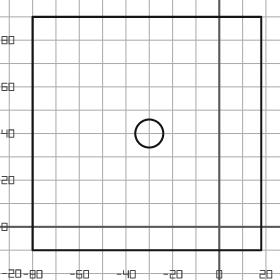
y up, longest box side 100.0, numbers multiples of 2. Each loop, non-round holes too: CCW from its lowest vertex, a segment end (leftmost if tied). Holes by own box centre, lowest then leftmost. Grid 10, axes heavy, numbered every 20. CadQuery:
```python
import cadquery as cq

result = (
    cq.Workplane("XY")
    .moveTo(-80.0, -10.0)
    .lineTo(18.0, -10.0)
    .lineTo(18.0, 90.0)
    .lineTo(-80.0, 90.0)
    .close()
    .moveTo(-30.0, 40.0)
    .circle(6.0)
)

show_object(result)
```